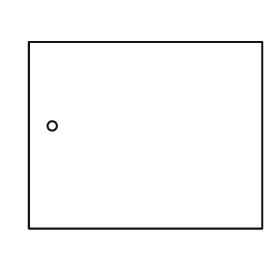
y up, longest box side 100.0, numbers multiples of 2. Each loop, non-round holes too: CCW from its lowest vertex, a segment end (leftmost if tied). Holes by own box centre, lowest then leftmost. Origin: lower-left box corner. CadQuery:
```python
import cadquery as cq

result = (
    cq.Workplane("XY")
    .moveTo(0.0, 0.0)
    .lineTo(100.0, 0.0)
    .lineTo(100.0, 80.0)
    .lineTo(0.0, 80.0)
    .close()
    .moveTo(10.0, 44.0)
    .circle(2.0)
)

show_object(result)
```